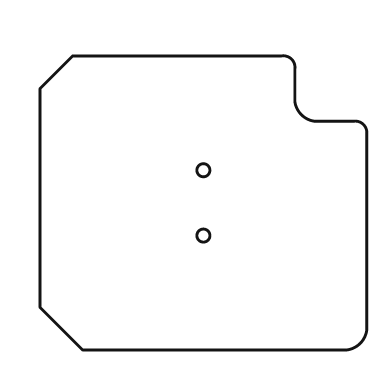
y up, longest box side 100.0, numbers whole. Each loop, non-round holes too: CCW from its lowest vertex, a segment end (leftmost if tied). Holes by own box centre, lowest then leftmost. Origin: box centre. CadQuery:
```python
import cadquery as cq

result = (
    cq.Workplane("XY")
    .moveTo(-37.0, -45.0)
    .lineTo(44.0, -45.0)
    .threePointArc((48.0, -43.0), (50.0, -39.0))
    .lineTo(50.0, 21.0)
    .threePointArc((49.0, 24.0), (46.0, 25.0))
    .lineTo(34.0, 25.0)
    .threePointArc((30.0, 27.0), (28.0, 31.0))
    .lineTo(28.0, 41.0)
    .threePointArc((27.0, 44.0), (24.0, 45.0))
    .lineTo(-40.0, 45.0)
    .lineTo(-50.0, 35.0)
    .lineTo(-50.0, -32.0)
    .close()
    .moveTo(0.0, -10.0)
    .circle(2.0)
    .moveTo(0.0, 10.0)
    .circle(2.0)
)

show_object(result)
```